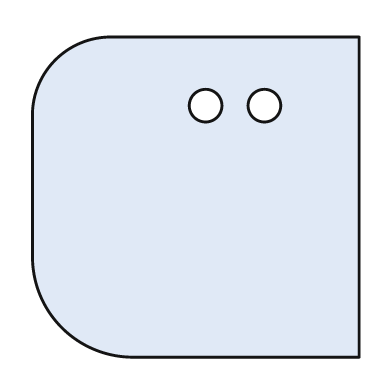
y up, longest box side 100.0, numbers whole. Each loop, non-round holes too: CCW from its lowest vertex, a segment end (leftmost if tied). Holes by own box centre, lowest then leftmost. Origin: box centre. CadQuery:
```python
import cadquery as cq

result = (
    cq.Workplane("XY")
    .moveTo(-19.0, -49.0)
    .lineTo(50.0, -49.0)
    .lineTo(50.0, 49.0)
    .lineTo(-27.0, 49.0)
    .threePointArc((-43.0, 42.0), (-50.0, 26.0))
    .lineTo(-50.0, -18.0)
    .threePointArc((-41.0, -40.0), (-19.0, -49.0))
    .close()
    .moveTo(3.0, 28.0)
    .circle(5.0)
    .moveTo(21.0, 28.0)
    .circle(5.0)
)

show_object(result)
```